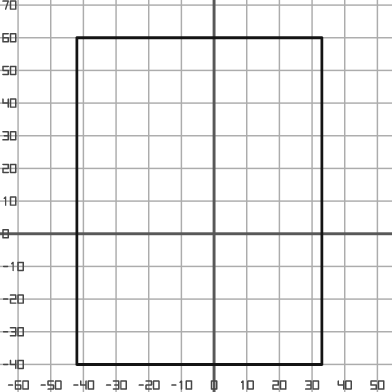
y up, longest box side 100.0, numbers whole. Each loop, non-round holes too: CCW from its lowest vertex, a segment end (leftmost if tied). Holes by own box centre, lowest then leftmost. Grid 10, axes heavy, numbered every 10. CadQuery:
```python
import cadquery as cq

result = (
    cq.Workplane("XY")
    .moveTo(-42.0, -40.0)
    .lineTo(33.0, -40.0)
    .lineTo(33.0, 60.0)
    .lineTo(-42.0, 60.0)
    .close()
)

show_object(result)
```